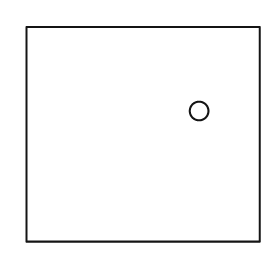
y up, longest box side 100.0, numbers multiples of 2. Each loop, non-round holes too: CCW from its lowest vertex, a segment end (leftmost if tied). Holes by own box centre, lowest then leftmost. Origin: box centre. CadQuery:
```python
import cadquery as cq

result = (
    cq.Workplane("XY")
    .moveTo(-50.0, -46.0)
    .lineTo(50.0, -46.0)
    .lineTo(50.0, 46.0)
    .lineTo(-50.0, 46.0)
    .close()
    .moveTo(24.0, 10.0)
    .circle(4.0)
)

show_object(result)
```